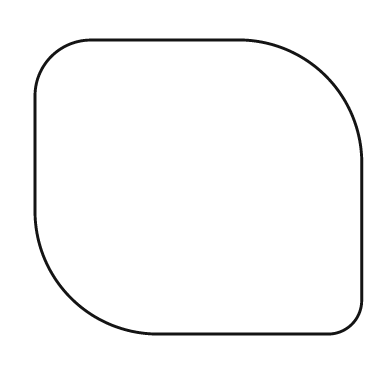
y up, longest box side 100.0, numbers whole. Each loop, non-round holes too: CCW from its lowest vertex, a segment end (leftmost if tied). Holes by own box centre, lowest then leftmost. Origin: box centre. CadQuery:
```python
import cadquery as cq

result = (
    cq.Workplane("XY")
    .moveTo(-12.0, -45.0)
    .lineTo(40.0, -45.0)
    .threePointArc((47.0, -42.0), (50.0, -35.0))
    .lineTo(50.0, 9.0)
    .threePointArc((39.0, 34.0), (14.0, 45.0))
    .lineTo(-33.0, 45.0)
    .threePointArc((-45.0, 40.0), (-50.0, 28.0))
    .lineTo(-50.0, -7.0)
    .threePointArc((-39.0, -34.0), (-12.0, -45.0))
    .close()
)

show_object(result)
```